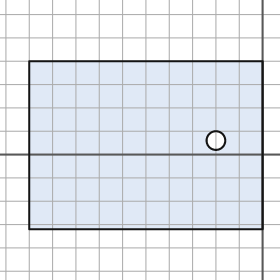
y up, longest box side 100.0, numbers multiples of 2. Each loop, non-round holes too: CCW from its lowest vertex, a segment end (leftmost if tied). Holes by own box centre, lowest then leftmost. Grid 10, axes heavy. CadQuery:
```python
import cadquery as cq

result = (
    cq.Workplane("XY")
    .moveTo(-100.0, -32.0)
    .lineTo(0.0, -32.0)
    .lineTo(0.0, 40.0)
    .lineTo(-100.0, 40.0)
    .close()
    .moveTo(-20.0, 6.0)
    .circle(4.0)
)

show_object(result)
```